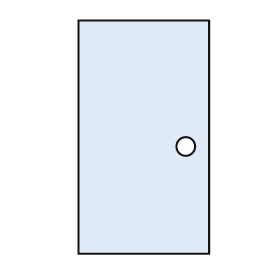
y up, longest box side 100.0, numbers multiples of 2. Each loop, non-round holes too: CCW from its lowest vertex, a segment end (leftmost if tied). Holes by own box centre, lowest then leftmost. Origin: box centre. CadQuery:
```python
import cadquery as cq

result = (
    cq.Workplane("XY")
    .moveTo(-28.0, -50.0)
    .lineTo(28.0, -50.0)
    .lineTo(28.0, 50.0)
    .lineTo(-28.0, 50.0)
    .close()
    .moveTo(18.0, -4.0)
    .circle(4.0)
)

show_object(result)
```